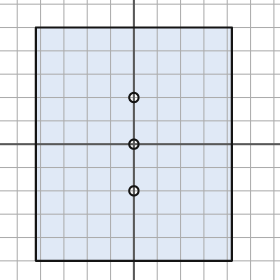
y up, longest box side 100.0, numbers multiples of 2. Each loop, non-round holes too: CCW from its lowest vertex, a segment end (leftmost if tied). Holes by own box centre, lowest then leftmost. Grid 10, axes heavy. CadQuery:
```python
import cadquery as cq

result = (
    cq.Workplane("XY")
    .moveTo(-42.0, -50.0)
    .lineTo(42.0, -50.0)
    .lineTo(42.0, 50.0)
    .lineTo(-42.0, 50.0)
    .close()
    .moveTo(0.0, -20.0)
    .circle(2.0)
    .moveTo(0.0, 0.0)
    .circle(2.0)
    .moveTo(0.0, 20.0)
    .circle(2.0)
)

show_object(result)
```